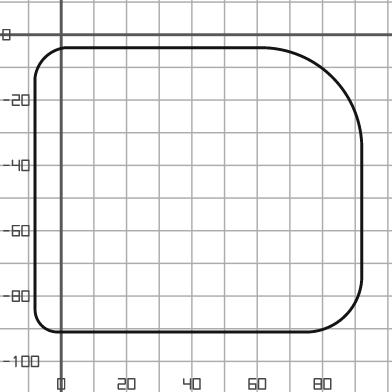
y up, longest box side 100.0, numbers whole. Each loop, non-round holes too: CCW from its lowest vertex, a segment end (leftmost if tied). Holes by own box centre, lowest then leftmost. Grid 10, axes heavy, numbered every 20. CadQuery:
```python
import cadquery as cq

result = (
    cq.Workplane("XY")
    .moveTo(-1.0, -91.0)
    .lineTo(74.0, -91.0)
    .threePointArc((87.0, -86.0), (92.0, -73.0))
    .lineTo(92.0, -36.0)
    .threePointArc((83.0, -13.0), (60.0, -4.0))
    .lineTo(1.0, -4.0)
    .threePointArc((-5.0, -7.0), (-8.0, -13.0))
    .lineTo(-8.0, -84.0)
    .threePointArc((-6.0, -89.0), (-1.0, -91.0))
    .close()
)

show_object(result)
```